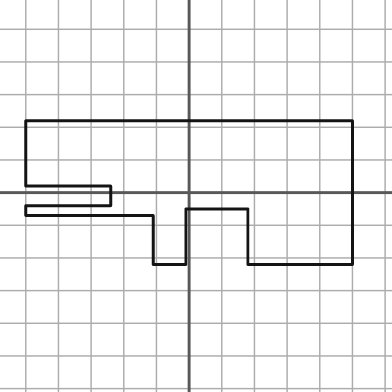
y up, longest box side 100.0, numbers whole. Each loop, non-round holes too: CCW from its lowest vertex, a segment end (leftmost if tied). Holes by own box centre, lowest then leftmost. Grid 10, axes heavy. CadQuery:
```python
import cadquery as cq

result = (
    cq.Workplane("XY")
    .moveTo(-11.0, -22.0)
    .lineTo(-1.0, -22.0)
    .lineTo(-1.0, -5.0)
    .lineTo(18.0, -5.0)
    .lineTo(18.0, -22.0)
    .lineTo(50.0, -22.0)
    .lineTo(50.0, 22.0)
    .lineTo(-50.0, 22.0)
    .lineTo(-50.0, 2.0)
    .lineTo(-24.0, 2.0)
    .lineTo(-24.0, -4.0)
    .lineTo(-50.0, -4.0)
    .lineTo(-50.0, -7.0)
    .lineTo(-11.0, -7.0)
    .close()
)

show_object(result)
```